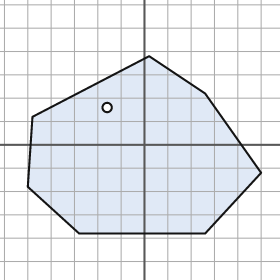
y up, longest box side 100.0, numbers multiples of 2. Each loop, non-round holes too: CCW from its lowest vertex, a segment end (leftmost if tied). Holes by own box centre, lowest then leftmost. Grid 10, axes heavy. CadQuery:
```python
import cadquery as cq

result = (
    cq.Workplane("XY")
    .moveTo(-28.0, -38.0)
    .lineTo(26.0, -38.0)
    .lineTo(50.0, -12.0)
    .lineTo(26.0, 22.0)
    .lineTo(2.0, 38.0)
    .lineTo(-48.0, 12.0)
    .lineTo(-50.0, -18.0)
    .close()
    .moveTo(-16.0, 16.0)
    .circle(2.0)
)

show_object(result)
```